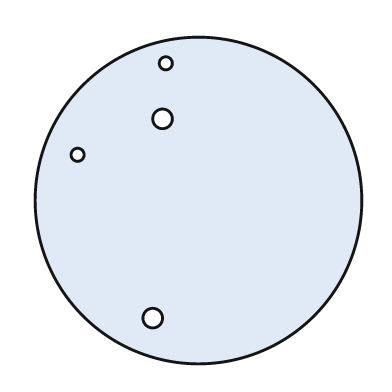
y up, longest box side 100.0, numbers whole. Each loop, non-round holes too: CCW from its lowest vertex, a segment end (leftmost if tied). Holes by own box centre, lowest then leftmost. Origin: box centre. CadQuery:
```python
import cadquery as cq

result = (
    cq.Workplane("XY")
    .moveTo(0.0, 0.0)
    .circle(50.0)
    .moveTo(-14.0, -36.0)
    .circle(3.0)
    .moveTo(-37.0, 14.0)
    .circle(2.0)
    .moveTo(-11.0, 25.0)
    .circle(3.0)
    .moveTo(-10.0, 42.0)
    .circle(2.0)
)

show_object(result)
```